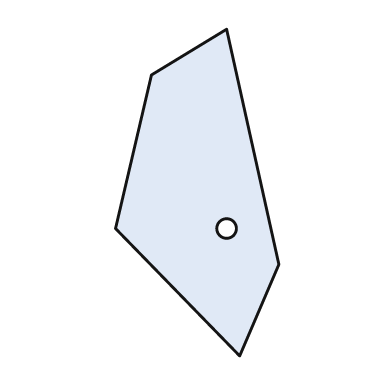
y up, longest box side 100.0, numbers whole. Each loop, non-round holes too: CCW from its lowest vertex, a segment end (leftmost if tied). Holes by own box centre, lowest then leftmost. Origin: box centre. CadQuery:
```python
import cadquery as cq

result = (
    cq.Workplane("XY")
    .moveTo(13.0, -50.0)
    .lineTo(25.0, -22.0)
    .lineTo(9.0, 50.0)
    .lineTo(-14.0, 36.0)
    .lineTo(-25.0, -11.0)
    .close()
    .moveTo(9.0, -11.0)
    .circle(3.0)
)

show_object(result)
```